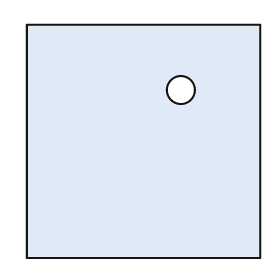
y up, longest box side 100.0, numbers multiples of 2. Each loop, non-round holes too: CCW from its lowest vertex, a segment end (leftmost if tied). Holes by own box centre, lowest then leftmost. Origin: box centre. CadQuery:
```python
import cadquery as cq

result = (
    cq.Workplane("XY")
    .moveTo(-50.0, -50.0)
    .lineTo(50.0, -50.0)
    .lineTo(50.0, 50.0)
    .lineTo(-50.0, 50.0)
    .close()
    .moveTo(16.0, 22.0)
    .circle(6.0)
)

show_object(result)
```